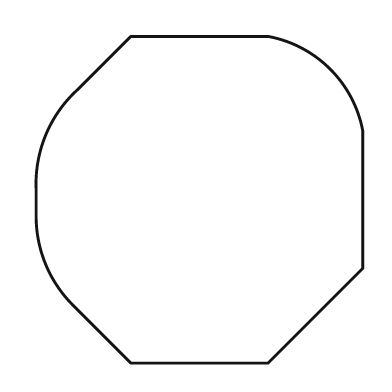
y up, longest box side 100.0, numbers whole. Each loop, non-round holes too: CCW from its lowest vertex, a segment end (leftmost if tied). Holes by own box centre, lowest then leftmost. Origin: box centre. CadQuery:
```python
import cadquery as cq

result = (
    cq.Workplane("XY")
    .moveTo(-21.0, -50.0)
    .lineTo(21.0, -50.0)
    .lineTo(50.0, -21.0)
    .lineTo(50.0, 21.0)
    .threePointArc((40.0, 40.0), (21.0, 50.0))
    .lineTo(-21.0, 50.0)
    .lineTo(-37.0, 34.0)
    .threePointArc((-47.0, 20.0), (-50.0, 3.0))
    .lineTo(-50.0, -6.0)
    .threePointArc((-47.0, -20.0), (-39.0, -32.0))
    .close()
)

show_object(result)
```